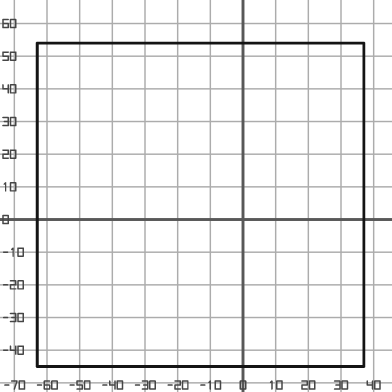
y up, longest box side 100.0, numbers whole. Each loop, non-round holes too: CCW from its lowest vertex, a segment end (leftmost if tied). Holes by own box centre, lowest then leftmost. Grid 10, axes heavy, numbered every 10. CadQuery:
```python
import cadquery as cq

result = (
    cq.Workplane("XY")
    .moveTo(-63.0, -45.0)
    .lineTo(37.0, -45.0)
    .lineTo(37.0, 54.0)
    .lineTo(-63.0, 54.0)
    .close()
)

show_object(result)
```